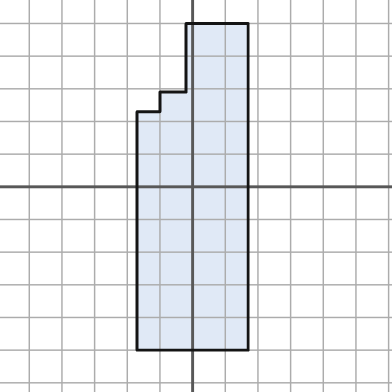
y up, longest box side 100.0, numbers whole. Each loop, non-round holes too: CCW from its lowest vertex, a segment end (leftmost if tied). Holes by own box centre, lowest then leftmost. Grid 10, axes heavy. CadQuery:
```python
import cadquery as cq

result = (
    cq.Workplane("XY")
    .moveTo(-17.0, -50.0)
    .lineTo(17.0, -50.0)
    .lineTo(17.0, 50.0)
    .lineTo(-2.0, 50.0)
    .lineTo(-2.0, 29.0)
    .lineTo(-10.0, 29.0)
    .lineTo(-10.0, 23.0)
    .lineTo(-17.0, 23.0)
    .close()
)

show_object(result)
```